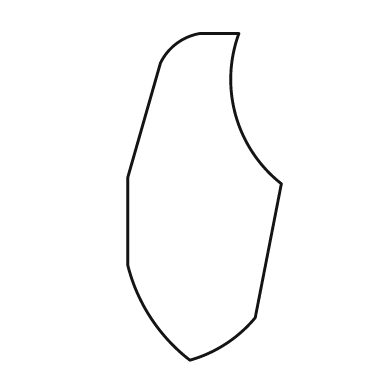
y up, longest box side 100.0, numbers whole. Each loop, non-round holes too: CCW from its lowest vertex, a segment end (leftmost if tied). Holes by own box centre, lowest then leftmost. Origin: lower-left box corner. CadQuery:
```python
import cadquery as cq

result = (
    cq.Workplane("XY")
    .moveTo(19.0, 0.0)
    .threePointArc((30.0, 5.0), (39.0, 13.0))
    .lineTo(47.0, 54.0)
    .threePointArc((33.0, 75.0), (34.0, 100.0))
    .lineTo(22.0, 100.0)
    .threePointArc((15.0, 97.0), (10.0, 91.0))
    .lineTo(0.0, 56.0)
    .lineTo(0.0, 29.0)
    .threePointArc((7.0, 13.0), (19.0, 0.0))
    .close()
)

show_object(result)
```